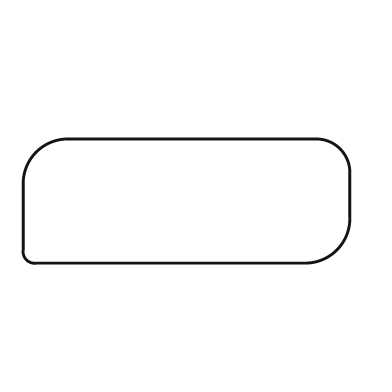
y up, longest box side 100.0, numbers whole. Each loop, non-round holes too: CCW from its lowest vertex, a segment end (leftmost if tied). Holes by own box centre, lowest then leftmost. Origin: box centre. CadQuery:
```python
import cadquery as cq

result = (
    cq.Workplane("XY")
    .moveTo(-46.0, -19.0)
    .lineTo(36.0, -19.0)
    .threePointArc((46.0, -15.0), (50.0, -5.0))
    .lineTo(50.0, 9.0)
    .threePointArc((47.0, 16.0), (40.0, 19.0))
    .lineTo(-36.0, 19.0)
    .threePointArc((-46.0, 15.0), (-50.0, 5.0))
    .lineTo(-50.0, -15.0)
    .threePointArc((-49.0, -18.0), (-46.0, -19.0))
    .close()
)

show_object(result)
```